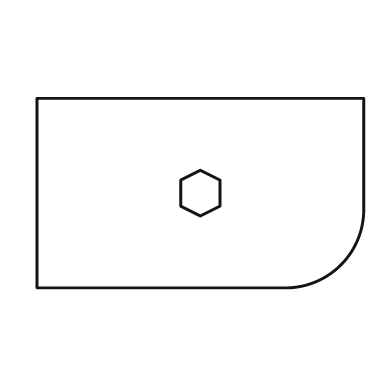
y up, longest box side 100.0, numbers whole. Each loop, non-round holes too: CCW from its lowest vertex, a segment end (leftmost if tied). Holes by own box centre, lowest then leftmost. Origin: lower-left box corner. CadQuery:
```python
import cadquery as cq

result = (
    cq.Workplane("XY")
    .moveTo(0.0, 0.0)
    .lineTo(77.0, 0.0)
    .threePointArc((93.0, 7.0), (100.0, 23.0))
    .lineTo(100.0, 58.0)
    .lineTo(0.0, 58.0)
    .close()
    .moveTo(50.0, 22.0)
    .lineTo(56.0, 25.0)
    .lineTo(56.0, 33.0)
    .lineTo(50.0, 36.0)
    .lineTo(44.0, 33.0)
    .lineTo(44.0, 25.0)
    .close()
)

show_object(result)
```